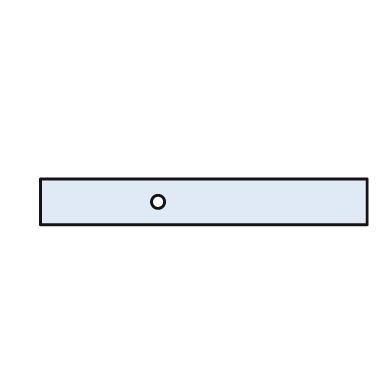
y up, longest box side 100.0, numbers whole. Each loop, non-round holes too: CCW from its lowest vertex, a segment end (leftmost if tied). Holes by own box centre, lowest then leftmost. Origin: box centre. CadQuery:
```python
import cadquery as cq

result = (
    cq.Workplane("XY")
    .moveTo(-50.0, -7.0)
    .lineTo(50.0, -7.0)
    .lineTo(50.0, 7.0)
    .lineTo(-50.0, 7.0)
    .close()
    .moveTo(-14.0, 0.0)
    .circle(2.0)
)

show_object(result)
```